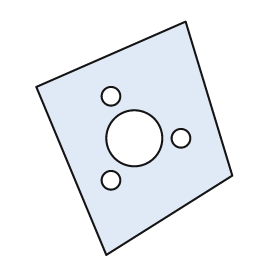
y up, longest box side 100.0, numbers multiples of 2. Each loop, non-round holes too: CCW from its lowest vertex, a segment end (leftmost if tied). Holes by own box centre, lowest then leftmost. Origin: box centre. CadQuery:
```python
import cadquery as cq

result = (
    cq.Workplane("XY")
    .moveTo(-12.0, -50.0)
    .lineTo(42.0, -16.0)
    .lineTo(22.0, 50.0)
    .lineTo(-42.0, 22.0)
    .close()
    .moveTo(-10.0, -18.0)
    .circle(4.0)
    .moveTo(0.0, 0.0)
    .circle(12.0)
    .moveTo(20.0, 0.0)
    .circle(4.0)
    .moveTo(-10.0, 18.0)
    .circle(4.0)
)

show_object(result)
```